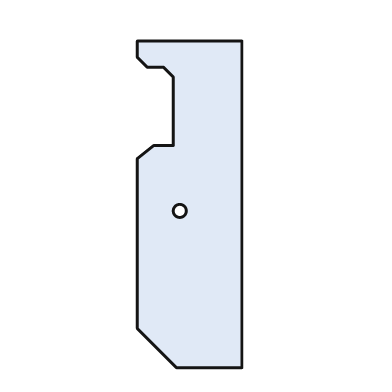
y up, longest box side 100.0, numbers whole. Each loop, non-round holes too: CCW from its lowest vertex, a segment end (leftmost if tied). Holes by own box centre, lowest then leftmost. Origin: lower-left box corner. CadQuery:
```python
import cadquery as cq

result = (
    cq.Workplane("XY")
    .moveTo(12.0, 0.0)
    .lineTo(32.0, 0.0)
    .lineTo(32.0, 100.0)
    .lineTo(0.0, 100.0)
    .lineTo(0.0, 95.0)
    .lineTo(3.0, 92.0)
    .lineTo(8.0, 92.0)
    .lineTo(11.0, 89.0)
    .lineTo(11.0, 68.0)
    .lineTo(5.0, 68.0)
    .lineTo(0.0, 64.0)
    .lineTo(0.0, 12.0)
    .close()
    .moveTo(13.0, 48.0)
    .circle(2.0)
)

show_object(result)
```